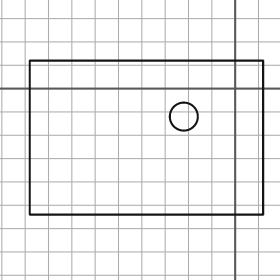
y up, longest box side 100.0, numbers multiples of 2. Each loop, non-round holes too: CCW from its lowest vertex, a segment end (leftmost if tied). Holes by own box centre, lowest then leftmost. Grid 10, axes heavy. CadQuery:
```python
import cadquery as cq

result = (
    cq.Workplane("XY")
    .moveTo(-88.0, -54.0)
    .lineTo(12.0, -54.0)
    .lineTo(12.0, 12.0)
    .lineTo(-88.0, 12.0)
    .close()
    .moveTo(-22.0, -12.0)
    .circle(6.0)
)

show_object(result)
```